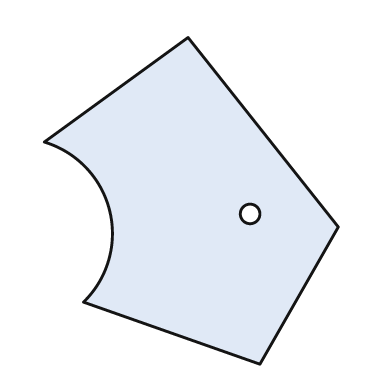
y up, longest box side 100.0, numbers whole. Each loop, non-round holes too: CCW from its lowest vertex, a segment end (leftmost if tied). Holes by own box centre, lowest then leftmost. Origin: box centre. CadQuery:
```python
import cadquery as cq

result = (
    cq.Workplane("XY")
    .moveTo(21.0, -50.0)
    .lineTo(45.0, -8.0)
    .lineTo(-1.0, 50.0)
    .lineTo(-45.0, 18.0)
    .threePointArc((-25.0, -3.0), (-33.0, -31.0))
    .close()
    .moveTo(18.0, -4.0)
    .circle(3.0)
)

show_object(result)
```